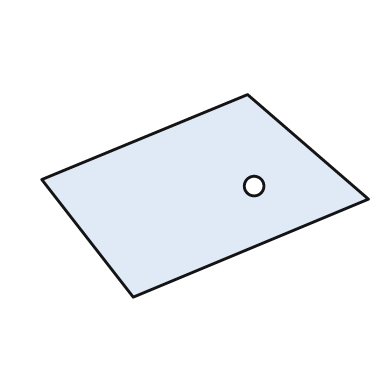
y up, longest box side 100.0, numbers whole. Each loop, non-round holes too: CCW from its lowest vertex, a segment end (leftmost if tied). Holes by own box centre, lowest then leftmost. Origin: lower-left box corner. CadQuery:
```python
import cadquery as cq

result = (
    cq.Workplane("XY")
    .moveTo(28.0, 0.0)
    .lineTo(100.0, 30.0)
    .lineTo(63.0, 62.0)
    .lineTo(0.0, 36.0)
    .close()
    .moveTo(65.0, 34.0)
    .circle(3.0)
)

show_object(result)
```